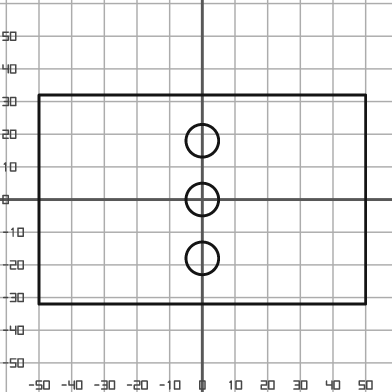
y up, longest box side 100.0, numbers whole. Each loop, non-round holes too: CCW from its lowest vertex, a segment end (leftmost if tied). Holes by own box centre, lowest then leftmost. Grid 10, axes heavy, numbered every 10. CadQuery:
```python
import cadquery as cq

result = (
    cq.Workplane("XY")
    .moveTo(-50.0, -32.0)
    .lineTo(50.0, -32.0)
    .lineTo(50.0, 32.0)
    .lineTo(-50.0, 32.0)
    .close()
    .moveTo(0.0, -18.0)
    .circle(5.0)
    .moveTo(0.0, 0.0)
    .circle(5.0)
    .moveTo(0.0, 18.0)
    .circle(5.0)
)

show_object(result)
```